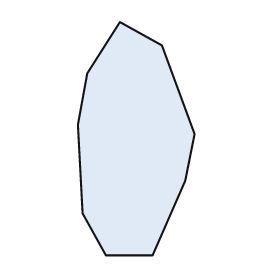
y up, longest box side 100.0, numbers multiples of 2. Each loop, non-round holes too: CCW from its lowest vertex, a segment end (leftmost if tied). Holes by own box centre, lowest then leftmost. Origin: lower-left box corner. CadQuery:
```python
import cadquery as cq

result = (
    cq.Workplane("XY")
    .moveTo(12.0, 0.0)
    .lineTo(32.0, 0.0)
    .lineTo(46.0, 32.0)
    .lineTo(50.0, 52.0)
    .lineTo(36.0, 90.0)
    .lineTo(18.0, 100.0)
    .lineTo(4.0, 78.0)
    .lineTo(0.0, 56.0)
    .lineTo(2.0, 18.0)
    .close()
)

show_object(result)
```